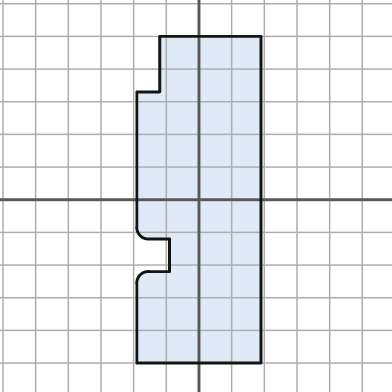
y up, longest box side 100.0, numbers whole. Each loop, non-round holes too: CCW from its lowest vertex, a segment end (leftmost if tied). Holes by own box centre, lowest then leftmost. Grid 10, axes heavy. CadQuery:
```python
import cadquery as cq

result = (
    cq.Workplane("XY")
    .moveTo(-19.0, -50.0)
    .lineTo(19.0, -50.0)
    .lineTo(19.0, 50.0)
    .lineTo(-12.0, 50.0)
    .lineTo(-12.0, 33.0)
    .lineTo(-19.0, 33.0)
    .lineTo(-19.0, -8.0)
    .threePointArc((-18.0, -11.0), (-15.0, -12.0))
    .lineTo(-9.0, -12.0)
    .lineTo(-9.0, -22.0)
    .lineTo(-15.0, -22.0)
    .threePointArc((-18.0, -23.0), (-19.0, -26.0))
    .close()
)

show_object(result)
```